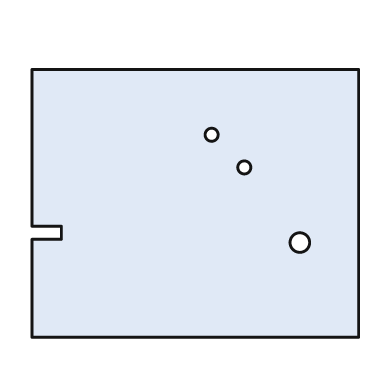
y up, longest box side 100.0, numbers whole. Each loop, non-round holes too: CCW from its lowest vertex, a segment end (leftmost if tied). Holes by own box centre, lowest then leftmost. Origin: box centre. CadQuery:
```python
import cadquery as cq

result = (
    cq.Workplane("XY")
    .moveTo(-50.0, -41.0)
    .lineTo(50.0, -41.0)
    .lineTo(50.0, 41.0)
    .lineTo(-50.0, 41.0)
    .lineTo(-50.0, -7.0)
    .lineTo(-41.0, -7.0)
    .lineTo(-41.0, -11.0)
    .lineTo(-50.0, -11.0)
    .close()
    .moveTo(32.0, -12.0)
    .circle(3.0)
    .moveTo(15.0, 11.0)
    .circle(2.0)
    .moveTo(5.0, 21.0)
    .circle(2.0)
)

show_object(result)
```